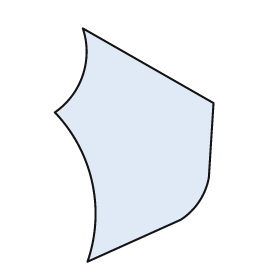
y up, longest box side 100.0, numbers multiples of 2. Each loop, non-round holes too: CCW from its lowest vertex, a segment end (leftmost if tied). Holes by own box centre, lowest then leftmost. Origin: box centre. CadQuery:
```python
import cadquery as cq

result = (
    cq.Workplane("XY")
    .moveTo(-20.0, -50.0)
    .lineTo(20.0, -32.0)
    .threePointArc((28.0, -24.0), (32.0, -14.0))
    .lineTo(34.0, 18.0)
    .lineTo(-22.0, 50.0)
    .threePointArc((-22.0, 30.0), (-34.0, 14.0))
    .threePointArc((-18.0, -16.0), (-20.0, -50.0))
    .close()
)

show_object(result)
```